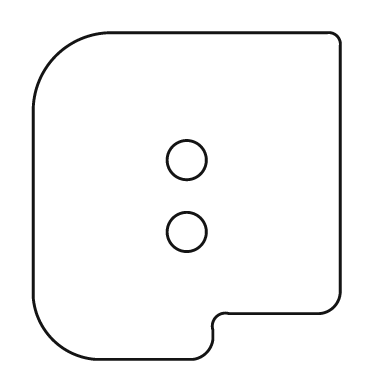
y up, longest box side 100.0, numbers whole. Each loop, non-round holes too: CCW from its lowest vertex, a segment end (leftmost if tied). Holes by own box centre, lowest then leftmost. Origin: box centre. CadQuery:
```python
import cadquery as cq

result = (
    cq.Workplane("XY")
    .moveTo(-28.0, -50.0)
    .lineTo(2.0, -50.0)
    .threePointArc((6.0, -48.0), (8.0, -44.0))
    .lineTo(8.0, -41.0)
    .threePointArc((9.0, -37.0), (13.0, -36.0))
    .lineTo(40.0, -36.0)
    .threePointArc((45.0, -34.0), (47.0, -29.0))
    .lineTo(47.0, 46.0)
    .threePointArc((46.0, 49.0), (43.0, 50.0))
    .lineTo(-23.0, 50.0)
    .threePointArc((-40.0, 43.0), (-47.0, 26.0))
    .lineTo(-47.0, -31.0)
    .threePointArc((-41.0, -44.0), (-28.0, -50.0))
    .close()
    .moveTo(0.0, -11.0)
    .circle(6.0)
    .moveTo(0.0, 11.0)
    .circle(6.0)
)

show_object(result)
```